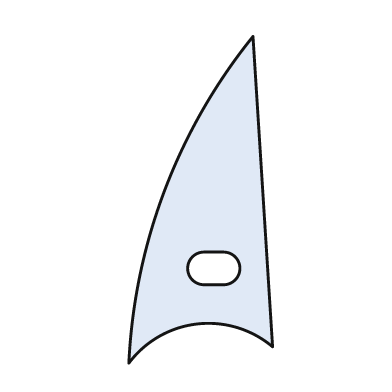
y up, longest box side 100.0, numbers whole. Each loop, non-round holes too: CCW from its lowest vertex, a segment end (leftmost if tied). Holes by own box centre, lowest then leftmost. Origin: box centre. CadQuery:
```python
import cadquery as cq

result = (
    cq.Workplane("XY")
    .moveTo(-22.0, -50.0)
    .threePointArc((-1.0, -38.0), (22.0, -45.0))
    .lineTo(16.0, 50.0)
    .threePointArc((-11.0, 3.0), (-22.0, -50.0))
    .close()
    .moveTo(1.0, -26.0)
    .lineTo(7.0, -26.0)
    .threePointArc((12.0, -21.0), (7.0, -16.0))
    .lineTo(1.0, -16.0)
    .threePointArc((-4.0, -21.0), (1.0, -26.0))
    .close()
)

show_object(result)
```